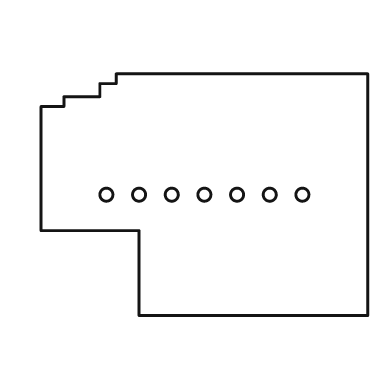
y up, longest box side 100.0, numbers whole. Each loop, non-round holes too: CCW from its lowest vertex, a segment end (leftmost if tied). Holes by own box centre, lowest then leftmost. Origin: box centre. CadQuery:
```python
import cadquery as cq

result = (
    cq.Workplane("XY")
    .moveTo(-20.0, -37.0)
    .lineTo(50.0, -37.0)
    .lineTo(50.0, 37.0)
    .lineTo(-27.0, 37.0)
    .lineTo(-27.0, 34.0)
    .lineTo(-32.0, 34.0)
    .lineTo(-32.0, 30.0)
    .lineTo(-43.0, 30.0)
    .lineTo(-43.0, 27.0)
    .lineTo(-50.0, 27.0)
    .lineTo(-50.0, -11.0)
    .lineTo(-20.0, -11.0)
    .close()
    .moveTo(-30.0, 0.0)
    .circle(2.0)
    .moveTo(-20.0, 0.0)
    .circle(2.0)
    .moveTo(-10.0, 0.0)
    .circle(2.0)
    .moveTo(0.0, 0.0)
    .circle(2.0)
    .moveTo(10.0, 0.0)
    .circle(2.0)
    .moveTo(20.0, 0.0)
    .circle(2.0)
    .moveTo(30.0, 0.0)
    .circle(2.0)
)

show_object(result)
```